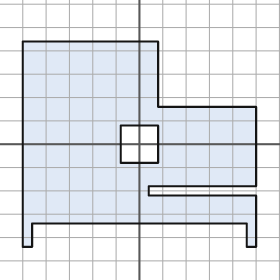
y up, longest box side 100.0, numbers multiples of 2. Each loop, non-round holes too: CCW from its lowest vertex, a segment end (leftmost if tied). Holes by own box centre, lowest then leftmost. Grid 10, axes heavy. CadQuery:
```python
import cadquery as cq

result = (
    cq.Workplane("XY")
    .moveTo(-50.0, -44.0)
    .lineTo(-46.0, -44.0)
    .lineTo(-46.0, -34.0)
    .lineTo(46.0, -34.0)
    .lineTo(46.0, -44.0)
    .lineTo(50.0, -44.0)
    .lineTo(50.0, -22.0)
    .lineTo(4.0, -22.0)
    .lineTo(4.0, -18.0)
    .lineTo(50.0, -18.0)
    .lineTo(50.0, 16.0)
    .lineTo(8.0, 16.0)
    .lineTo(8.0, 44.0)
    .lineTo(-50.0, 44.0)
    .close()
    .moveTo(-8.0, -8.0)
    .lineTo(8.0, -8.0)
    .lineTo(8.0, 8.0)
    .lineTo(-8.0, 8.0)
    .close()
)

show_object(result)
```